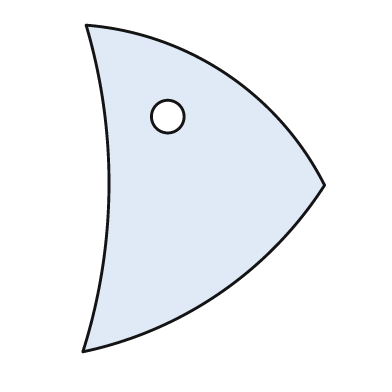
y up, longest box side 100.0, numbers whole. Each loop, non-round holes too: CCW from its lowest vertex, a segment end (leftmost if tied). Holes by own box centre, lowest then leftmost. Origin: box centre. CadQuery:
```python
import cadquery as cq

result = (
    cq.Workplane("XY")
    .moveTo(-37.0, -50.0)
    .threePointArc((5.0, -32.0), (37.0, 1.0))
    .threePointArc((7.0, 35.0), (-36.0, 50.0))
    .threePointArc((-29.0, 0.0), (-37.0, -50.0))
    .close()
    .moveTo(-11.0, 22.0)
    .circle(5.0)
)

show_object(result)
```